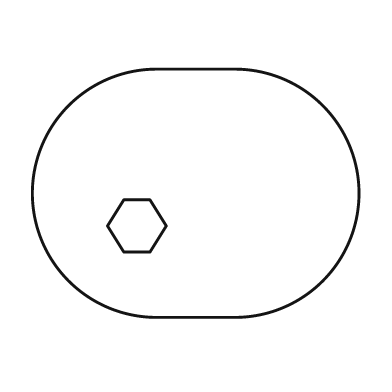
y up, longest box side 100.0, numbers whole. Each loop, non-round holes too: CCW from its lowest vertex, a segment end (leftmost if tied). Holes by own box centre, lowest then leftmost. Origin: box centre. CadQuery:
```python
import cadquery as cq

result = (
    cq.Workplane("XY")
    .moveTo(-12.0, -38.0)
    .lineTo(12.0, -38.0)
    .threePointArc((50.0, 0.0), (12.0, 38.0))
    .lineTo(-12.0, 38.0)
    .threePointArc((-50.0, 0.0), (-12.0, -38.0))
    .close()
    .moveTo(-22.0, -18.0)
    .lineTo(-14.0, -18.0)
    .lineTo(-9.0, -10.0)
    .lineTo(-14.0, -2.0)
    .lineTo(-22.0, -2.0)
    .lineTo(-27.0, -10.0)
    .close()
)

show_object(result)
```